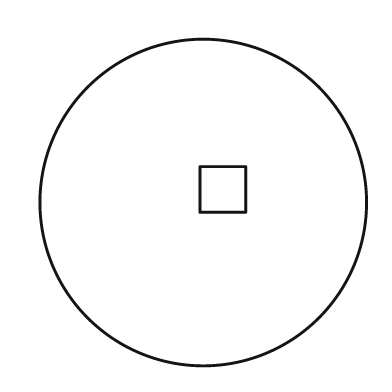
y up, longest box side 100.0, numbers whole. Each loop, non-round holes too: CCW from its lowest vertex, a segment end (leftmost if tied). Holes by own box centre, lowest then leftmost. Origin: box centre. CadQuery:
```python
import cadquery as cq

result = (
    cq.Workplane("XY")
    .moveTo(0.0, 0.0)
    .circle(50.0)
    .moveTo(-1.0, -3.0)
    .lineTo(13.0, -3.0)
    .lineTo(13.0, 11.0)
    .lineTo(-1.0, 11.0)
    .close()
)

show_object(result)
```